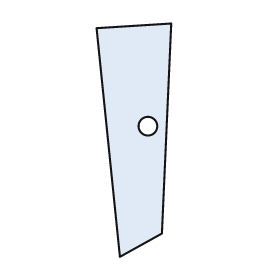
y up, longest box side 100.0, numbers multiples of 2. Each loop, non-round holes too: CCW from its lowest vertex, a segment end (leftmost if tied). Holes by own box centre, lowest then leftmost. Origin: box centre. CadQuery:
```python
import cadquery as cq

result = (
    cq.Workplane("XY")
    .moveTo(-6.0, -50.0)
    .lineTo(12.0, -40.0)
    .lineTo(16.0, 50.0)
    .lineTo(-16.0, 48.0)
    .close()
    .moveTo(6.0, 6.0)
    .circle(4.0)
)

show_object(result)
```